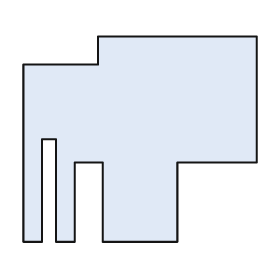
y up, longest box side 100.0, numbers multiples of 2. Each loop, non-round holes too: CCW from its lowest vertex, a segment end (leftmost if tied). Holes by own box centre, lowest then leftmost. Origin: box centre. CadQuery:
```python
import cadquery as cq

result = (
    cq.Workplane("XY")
    .moveTo(-50.0, -44.0)
    .lineTo(-42.0, -44.0)
    .lineTo(-42.0, 0.0)
    .lineTo(-36.0, 0.0)
    .lineTo(-36.0, -44.0)
    .lineTo(-28.0, -44.0)
    .lineTo(-28.0, -10.0)
    .lineTo(-16.0, -10.0)
    .lineTo(-16.0, -44.0)
    .lineTo(16.0, -44.0)
    .lineTo(16.0, -10.0)
    .lineTo(50.0, -10.0)
    .lineTo(50.0, 44.0)
    .lineTo(-18.0, 44.0)
    .lineTo(-18.0, 32.0)
    .lineTo(-50.0, 32.0)
    .close()
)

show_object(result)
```